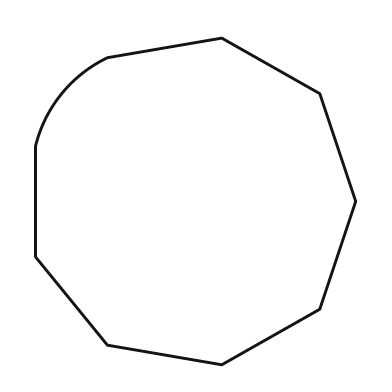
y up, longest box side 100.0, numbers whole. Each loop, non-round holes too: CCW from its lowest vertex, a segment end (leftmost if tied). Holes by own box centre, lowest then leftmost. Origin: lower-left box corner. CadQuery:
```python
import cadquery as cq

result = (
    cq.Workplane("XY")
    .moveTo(57.0, 0.0)
    .lineTo(87.0, 17.0)
    .lineTo(98.0, 50.0)
    .lineTo(87.0, 83.0)
    .lineTo(57.0, 100.0)
    .lineTo(22.0, 94.0)
    .threePointArc((8.0, 83.0), (0.0, 67.0))
    .lineTo(0.0, 33.0)
    .lineTo(22.0, 6.0)
    .close()
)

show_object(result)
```